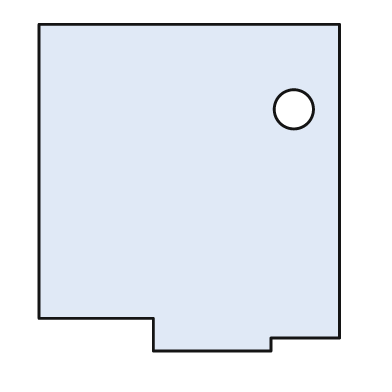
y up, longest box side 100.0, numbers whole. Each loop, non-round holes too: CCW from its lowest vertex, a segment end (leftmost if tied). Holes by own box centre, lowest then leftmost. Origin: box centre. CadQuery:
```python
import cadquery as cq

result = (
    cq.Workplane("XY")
    .moveTo(-11.0, -50.0)
    .lineTo(25.0, -50.0)
    .lineTo(25.0, -46.0)
    .lineTo(46.0, -46.0)
    .lineTo(46.0, 50.0)
    .lineTo(-46.0, 50.0)
    .lineTo(-46.0, -40.0)
    .lineTo(-11.0, -40.0)
    .close()
    .moveTo(32.0, 24.0)
    .circle(6.0)
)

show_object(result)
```